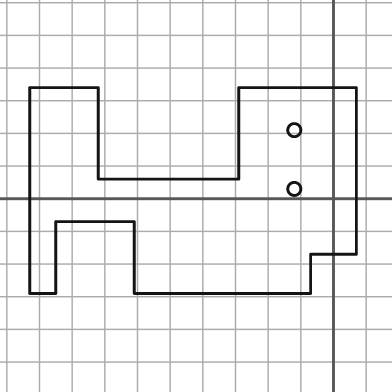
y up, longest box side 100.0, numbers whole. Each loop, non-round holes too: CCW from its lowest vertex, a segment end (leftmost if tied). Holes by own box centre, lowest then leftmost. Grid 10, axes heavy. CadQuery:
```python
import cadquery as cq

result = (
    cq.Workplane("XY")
    .moveTo(-93.0, -29.0)
    .lineTo(-85.0, -29.0)
    .lineTo(-85.0, -7.0)
    .lineTo(-61.0, -7.0)
    .lineTo(-61.0, -29.0)
    .lineTo(-7.0, -29.0)
    .lineTo(-7.0, -17.0)
    .lineTo(7.0, -17.0)
    .lineTo(7.0, 34.0)
    .lineTo(-29.0, 34.0)
    .lineTo(-29.0, 6.0)
    .lineTo(-72.0, 6.0)
    .lineTo(-72.0, 34.0)
    .lineTo(-93.0, 34.0)
    .close()
    .moveTo(-12.0, 3.0)
    .circle(2.0)
    .moveTo(-12.0, 21.0)
    .circle(2.0)
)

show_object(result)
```